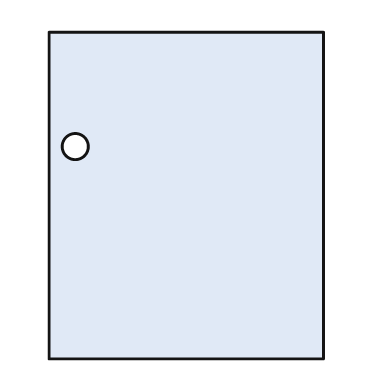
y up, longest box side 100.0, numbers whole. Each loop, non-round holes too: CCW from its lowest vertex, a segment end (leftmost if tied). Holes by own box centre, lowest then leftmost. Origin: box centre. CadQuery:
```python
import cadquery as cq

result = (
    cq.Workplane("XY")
    .moveTo(-42.0, -50.0)
    .lineTo(42.0, -50.0)
    .lineTo(42.0, 50.0)
    .lineTo(-42.0, 50.0)
    .close()
    .moveTo(-34.0, 15.0)
    .circle(4.0)
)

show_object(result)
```